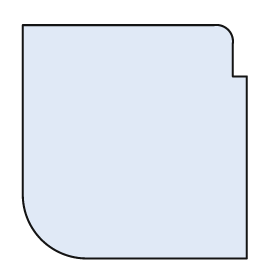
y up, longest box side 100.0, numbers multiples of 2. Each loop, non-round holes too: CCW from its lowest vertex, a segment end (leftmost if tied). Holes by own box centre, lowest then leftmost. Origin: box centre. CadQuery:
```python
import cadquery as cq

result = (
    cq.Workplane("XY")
    .moveTo(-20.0, -50.0)
    .lineTo(48.0, -50.0)
    .lineTo(48.0, 28.0)
    .lineTo(42.0, 28.0)
    .lineTo(42.0, 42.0)
    .threePointArc((40.0, 48.0), (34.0, 50.0))
    .lineTo(-48.0, 50.0)
    .lineTo(-48.0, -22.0)
    .threePointArc((-40.0, -42.0), (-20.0, -50.0))
    .close()
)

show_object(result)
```